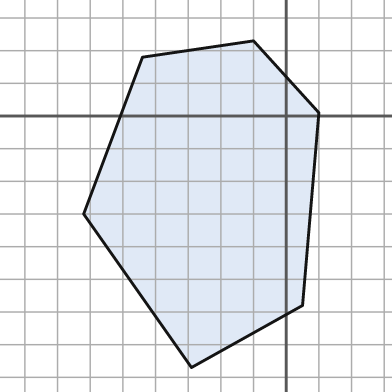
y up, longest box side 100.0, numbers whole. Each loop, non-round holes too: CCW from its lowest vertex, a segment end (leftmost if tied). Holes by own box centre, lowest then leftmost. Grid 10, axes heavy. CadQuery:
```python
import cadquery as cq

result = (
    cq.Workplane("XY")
    .moveTo(-29.0, -77.0)
    .lineTo(5.0, -58.0)
    .lineTo(10.0, 1.0)
    .lineTo(-10.0, 23.0)
    .lineTo(-44.0, 18.0)
    .lineTo(-62.0, -30.0)
    .close()
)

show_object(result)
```